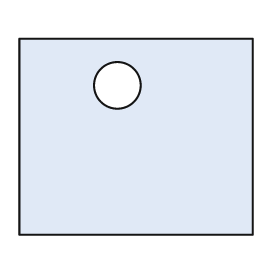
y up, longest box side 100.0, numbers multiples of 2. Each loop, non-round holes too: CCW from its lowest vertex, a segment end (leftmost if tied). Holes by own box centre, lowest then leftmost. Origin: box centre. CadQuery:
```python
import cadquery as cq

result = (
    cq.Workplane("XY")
    .moveTo(-50.0, -42.0)
    .lineTo(50.0, -42.0)
    .lineTo(50.0, 42.0)
    .lineTo(-50.0, 42.0)
    .close()
    .moveTo(-8.0, 22.0)
    .circle(10.0)
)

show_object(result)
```